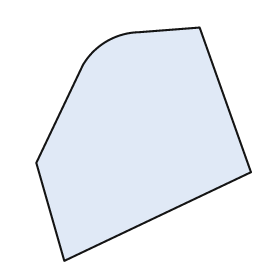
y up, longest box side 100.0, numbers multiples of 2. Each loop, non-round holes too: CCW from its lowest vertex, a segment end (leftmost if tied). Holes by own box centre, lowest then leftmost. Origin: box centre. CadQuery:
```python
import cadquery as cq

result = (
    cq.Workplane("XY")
    .moveTo(-34.0, -50.0)
    .lineTo(46.0, -12.0)
    .lineTo(24.0, 50.0)
    .lineTo(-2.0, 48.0)
    .threePointArc((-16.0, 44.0), (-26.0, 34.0))
    .lineTo(-46.0, -8.0)
    .close()
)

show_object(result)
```